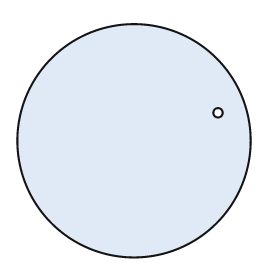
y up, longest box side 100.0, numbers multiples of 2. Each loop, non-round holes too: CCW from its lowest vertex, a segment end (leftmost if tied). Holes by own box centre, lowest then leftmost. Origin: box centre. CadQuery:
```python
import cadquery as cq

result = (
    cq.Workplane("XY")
    .moveTo(0.0, 0.0)
    .circle(50.0)
    .moveTo(36.0, 12.0)
    .circle(2.0)
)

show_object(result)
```